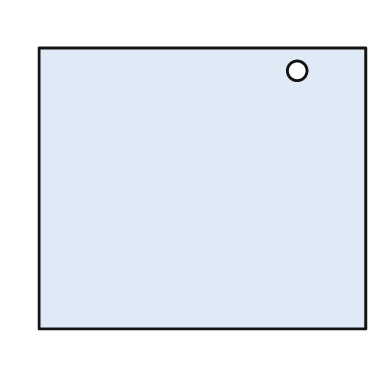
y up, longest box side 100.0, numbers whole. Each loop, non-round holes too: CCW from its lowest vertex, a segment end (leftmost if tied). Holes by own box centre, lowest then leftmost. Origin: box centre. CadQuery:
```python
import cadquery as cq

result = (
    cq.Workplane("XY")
    .moveTo(-50.0, -43.0)
    .lineTo(50.0, -43.0)
    .lineTo(50.0, 43.0)
    .lineTo(-50.0, 43.0)
    .close()
    .moveTo(29.0, 36.0)
    .circle(3.0)
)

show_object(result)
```